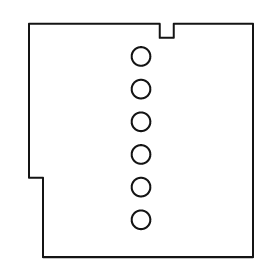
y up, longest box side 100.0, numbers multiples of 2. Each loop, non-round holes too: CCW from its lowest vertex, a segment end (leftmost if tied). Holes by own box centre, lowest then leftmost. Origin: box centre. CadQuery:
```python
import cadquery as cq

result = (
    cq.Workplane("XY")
    .moveTo(-42.0, -50.0)
    .lineTo(48.0, -50.0)
    .lineTo(48.0, 50.0)
    .lineTo(14.0, 50.0)
    .lineTo(14.0, 44.0)
    .lineTo(8.0, 44.0)
    .lineTo(8.0, 50.0)
    .lineTo(-48.0, 50.0)
    .lineTo(-48.0, -16.0)
    .lineTo(-42.0, -16.0)
    .close()
    .moveTo(0.0, -34.0)
    .circle(4.0)
    .moveTo(0.0, -20.0)
    .circle(4.0)
    .moveTo(0.0, -6.0)
    .circle(4.0)
    .moveTo(0.0, 8.0)
    .circle(4.0)
    .moveTo(0.0, 22.0)
    .circle(4.0)
    .moveTo(0.0, 36.0)
    .circle(4.0)
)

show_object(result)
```